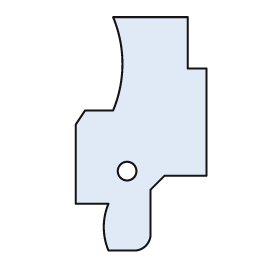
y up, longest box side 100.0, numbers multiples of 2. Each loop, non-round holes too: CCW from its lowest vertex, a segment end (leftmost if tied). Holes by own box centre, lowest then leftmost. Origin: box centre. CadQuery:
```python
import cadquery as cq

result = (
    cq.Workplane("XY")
    .moveTo(-14.0, -50.0)
    .lineTo(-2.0, -50.0)
    .threePointArc((2.0, -48.0), (4.0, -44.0))
    .lineTo(4.0, -24.0)
    .lineTo(10.0, -18.0)
    .lineTo(28.0, -18.0)
    .lineTo(28.0, 28.0)
    .lineTo(20.0, 28.0)
    .lineTo(20.0, 50.0)
    .lineTo(-12.0, 50.0)
    .threePointArc((-8.0, 30.0), (-12.0, 10.0))
    .lineTo(-24.0, 10.0)
    .lineTo(-28.0, 4.0)
    .lineTo(-28.0, -30.0)
    .lineTo(-14.0, -30.0)
    .threePointArc((-16.0, -40.0), (-14.0, -50.0))
    .close()
    .moveTo(-6.0, -16.0)
    .circle(4.0)
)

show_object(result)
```